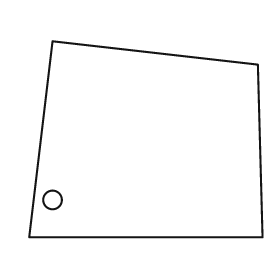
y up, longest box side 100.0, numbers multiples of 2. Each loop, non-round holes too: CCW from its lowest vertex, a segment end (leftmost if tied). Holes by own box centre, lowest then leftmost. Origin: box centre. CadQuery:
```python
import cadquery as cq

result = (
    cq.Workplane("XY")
    .moveTo(-50.0, -42.0)
    .lineTo(50.0, -42.0)
    .lineTo(48.0, 32.0)
    .lineTo(-40.0, 42.0)
    .close()
    .moveTo(-40.0, -26.0)
    .circle(4.0)
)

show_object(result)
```